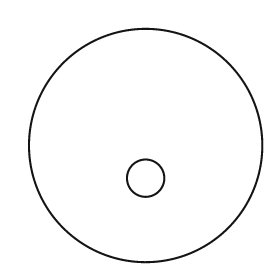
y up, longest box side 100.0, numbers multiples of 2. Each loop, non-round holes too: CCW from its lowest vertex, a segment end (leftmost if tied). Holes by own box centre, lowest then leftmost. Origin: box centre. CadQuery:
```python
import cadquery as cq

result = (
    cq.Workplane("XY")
    .moveTo(0.0, 0.0)
    .circle(50.0)
    .moveTo(0.0, -14.0)
    .circle(8.0)
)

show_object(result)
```